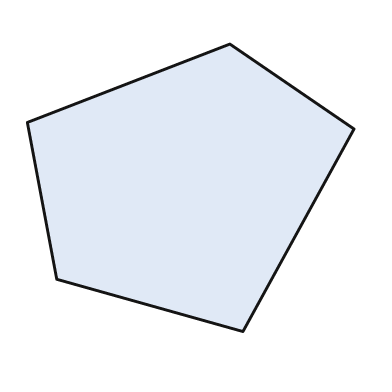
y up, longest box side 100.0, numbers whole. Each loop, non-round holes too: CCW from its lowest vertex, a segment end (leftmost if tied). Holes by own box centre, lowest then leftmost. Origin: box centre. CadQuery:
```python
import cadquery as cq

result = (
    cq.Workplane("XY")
    .moveTo(16.0, -44.0)
    .lineTo(50.0, 18.0)
    .lineTo(12.0, 44.0)
    .lineTo(-50.0, 20.0)
    .lineTo(-41.0, -28.0)
    .close()
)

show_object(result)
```